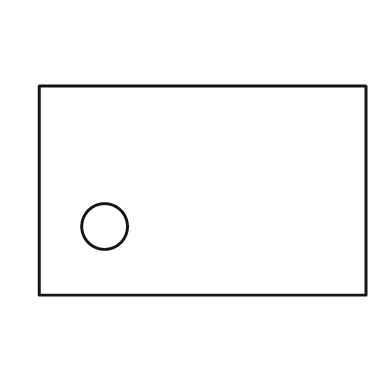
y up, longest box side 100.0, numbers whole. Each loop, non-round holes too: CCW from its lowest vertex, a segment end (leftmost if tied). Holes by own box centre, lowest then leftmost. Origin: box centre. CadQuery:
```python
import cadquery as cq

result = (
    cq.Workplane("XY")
    .moveTo(-50.0, -32.0)
    .lineTo(50.0, -32.0)
    .lineTo(50.0, 32.0)
    .lineTo(-50.0, 32.0)
    .close()
    .moveTo(-30.0, -11.0)
    .circle(7.0)
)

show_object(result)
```